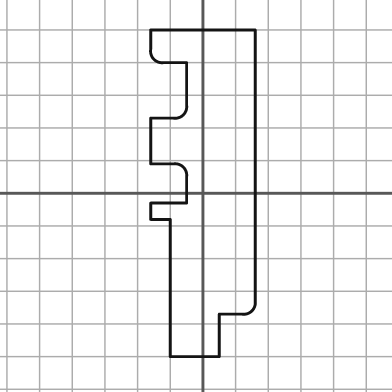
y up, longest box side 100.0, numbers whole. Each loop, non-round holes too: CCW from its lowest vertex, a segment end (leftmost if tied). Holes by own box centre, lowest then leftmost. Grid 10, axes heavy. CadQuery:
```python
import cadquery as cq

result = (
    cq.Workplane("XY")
    .moveTo(-10.0, -50.0)
    .lineTo(5.0, -50.0)
    .lineTo(5.0, -37.0)
    .lineTo(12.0, -37.0)
    .threePointArc((15.0, -36.0), (16.0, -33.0))
    .lineTo(16.0, 50.0)
    .lineTo(-16.0, 50.0)
    .lineTo(-16.0, 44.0)
    .threePointArc((-15.0, 41.0), (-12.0, 40.0))
    .lineTo(-5.0, 40.0)
    .lineTo(-5.0, 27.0)
    .threePointArc((-6.0, 24.0), (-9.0, 23.0))
    .lineTo(-16.0, 23.0)
    .lineTo(-16.0, 9.0)
    .lineTo(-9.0, 9.0)
    .threePointArc((-6.0, 8.0), (-5.0, 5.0))
    .lineTo(-5.0, -3.0)
    .lineTo(-16.0, -3.0)
    .lineTo(-16.0, -8.0)
    .lineTo(-10.0, -8.0)
    .close()
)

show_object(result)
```